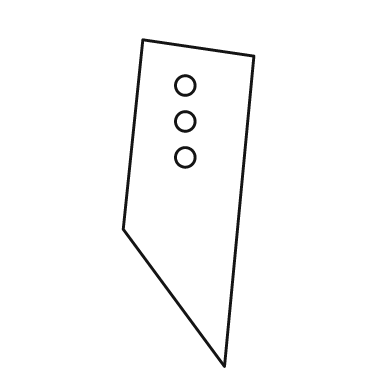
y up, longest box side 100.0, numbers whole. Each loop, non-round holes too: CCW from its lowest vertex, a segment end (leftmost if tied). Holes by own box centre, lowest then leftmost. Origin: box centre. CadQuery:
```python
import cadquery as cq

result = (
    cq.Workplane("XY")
    .moveTo(11.0, -50.0)
    .lineTo(20.0, 45.0)
    .lineTo(-14.0, 50.0)
    .lineTo(-20.0, -8.0)
    .close()
    .moveTo(-1.0, 14.0)
    .circle(3.0)
    .moveTo(-1.0, 25.0)
    .circle(3.0)
    .moveTo(-1.0, 36.0)
    .circle(3.0)
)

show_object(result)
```